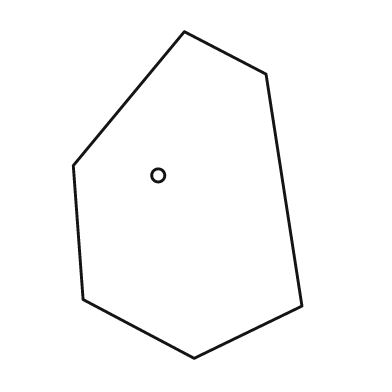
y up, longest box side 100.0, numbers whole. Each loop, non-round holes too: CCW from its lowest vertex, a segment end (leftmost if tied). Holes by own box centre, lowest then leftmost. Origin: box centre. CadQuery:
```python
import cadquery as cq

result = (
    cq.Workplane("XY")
    .moveTo(2.0, -50.0)
    .lineTo(35.0, -34.0)
    .lineTo(24.0, 37.0)
    .lineTo(-1.0, 50.0)
    .lineTo(-35.0, 9.0)
    .lineTo(-32.0, -32.0)
    .close()
    .moveTo(-9.0, 6.0)
    .circle(2.0)
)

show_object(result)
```